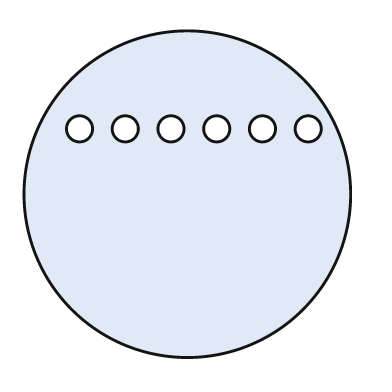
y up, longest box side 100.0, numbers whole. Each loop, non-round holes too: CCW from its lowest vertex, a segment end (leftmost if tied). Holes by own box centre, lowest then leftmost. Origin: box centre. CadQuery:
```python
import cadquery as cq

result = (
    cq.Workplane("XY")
    .moveTo(0.0, 0.0)
    .circle(50.0)
    .moveTo(-33.0, 20.0)
    .circle(4.0)
    .moveTo(-19.0, 20.0)
    .circle(4.0)
    .moveTo(-5.0, 20.0)
    .circle(4.0)
    .moveTo(9.0, 20.0)
    .circle(4.0)
    .moveTo(23.0, 20.0)
    .circle(4.0)
    .moveTo(37.0, 20.0)
    .circle(4.0)
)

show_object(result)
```